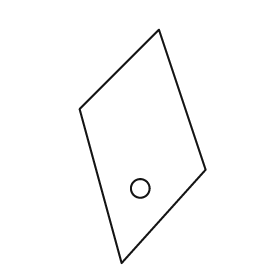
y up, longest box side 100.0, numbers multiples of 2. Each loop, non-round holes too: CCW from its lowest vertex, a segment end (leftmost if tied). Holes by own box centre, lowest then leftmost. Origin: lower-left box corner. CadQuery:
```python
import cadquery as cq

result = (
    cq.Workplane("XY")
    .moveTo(18.0, 0.0)
    .lineTo(54.0, 40.0)
    .lineTo(34.0, 100.0)
    .lineTo(0.0, 66.0)
    .close()
    .moveTo(26.0, 32.0)
    .circle(4.0)
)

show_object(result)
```